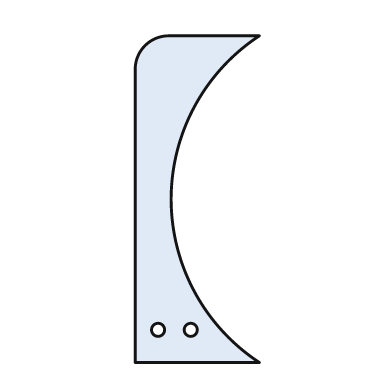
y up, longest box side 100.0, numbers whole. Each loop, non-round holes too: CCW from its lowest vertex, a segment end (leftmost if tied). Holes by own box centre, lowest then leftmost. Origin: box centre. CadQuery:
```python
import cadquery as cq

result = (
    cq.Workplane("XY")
    .moveTo(-19.0, -50.0)
    .lineTo(19.0, -50.0)
    .threePointArc((-8.0, 0.0), (19.0, 50.0))
    .lineTo(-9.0, 50.0)
    .threePointArc((-16.0, 47.0), (-19.0, 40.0))
    .close()
    .moveTo(-12.0, -40.0)
    .circle(2.0)
    .moveTo(-2.0, -40.0)
    .circle(2.0)
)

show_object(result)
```